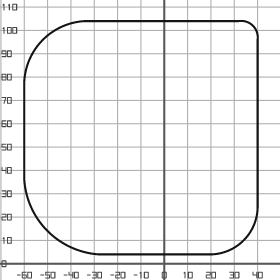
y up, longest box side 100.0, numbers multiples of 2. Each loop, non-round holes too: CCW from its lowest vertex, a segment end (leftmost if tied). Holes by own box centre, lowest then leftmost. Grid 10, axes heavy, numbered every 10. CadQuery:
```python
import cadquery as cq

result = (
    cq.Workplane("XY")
    .moveTo(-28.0, 4.0)
    .lineTo(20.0, 4.0)
    .threePointArc((34.0, 10.0), (40.0, 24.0))
    .lineTo(40.0, 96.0)
    .threePointArc((38.0, 102.0), (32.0, 104.0))
    .lineTo(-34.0, 104.0)
    .threePointArc((-52.0, 96.0), (-60.0, 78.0))
    .lineTo(-60.0, 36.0)
    .threePointArc((-50.0, 14.0), (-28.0, 4.0))
    .close()
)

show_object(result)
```